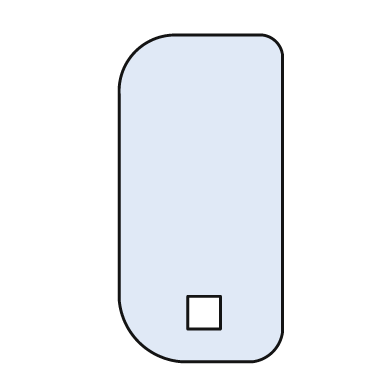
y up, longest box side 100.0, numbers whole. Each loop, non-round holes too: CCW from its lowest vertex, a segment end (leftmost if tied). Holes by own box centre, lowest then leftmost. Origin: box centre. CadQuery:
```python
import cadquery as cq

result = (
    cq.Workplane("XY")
    .moveTo(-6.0, -50.0)
    .lineTo(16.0, -50.0)
    .threePointArc((22.0, -47.0), (25.0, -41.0))
    .lineTo(25.0, 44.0)
    .threePointArc((23.0, 48.0), (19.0, 50.0))
    .lineTo(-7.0, 50.0)
    .threePointArc((-20.0, 45.0), (-25.0, 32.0))
    .lineTo(-25.0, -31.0)
    .threePointArc((-19.0, -44.0), (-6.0, -50.0))
    .close()
    .moveTo(-4.0, -40.0)
    .lineTo(6.0, -40.0)
    .lineTo(6.0, -30.0)
    .lineTo(-4.0, -30.0)
    .close()
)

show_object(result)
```